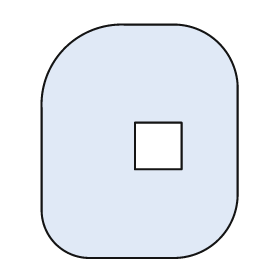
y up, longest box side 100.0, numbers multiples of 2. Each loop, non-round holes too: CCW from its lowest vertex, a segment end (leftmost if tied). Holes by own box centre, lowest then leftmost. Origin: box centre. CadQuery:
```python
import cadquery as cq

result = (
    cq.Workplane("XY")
    .moveTo(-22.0, -50.0)
    .lineTo(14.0, -50.0)
    .threePointArc((34.0, -42.0), (42.0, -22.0))
    .lineTo(42.0, 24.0)
    .threePointArc((34.0, 42.0), (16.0, 50.0))
    .lineTo(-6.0, 50.0)
    .threePointArc((-32.0, 40.0), (-42.0, 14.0))
    .lineTo(-42.0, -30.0)
    .threePointArc((-36.0, -44.0), (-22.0, -50.0))
    .close()
    .moveTo(-2.0, -12.0)
    .lineTo(18.0, -12.0)
    .lineTo(18.0, 8.0)
    .lineTo(-2.0, 8.0)
    .close()
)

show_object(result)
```